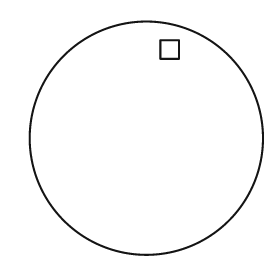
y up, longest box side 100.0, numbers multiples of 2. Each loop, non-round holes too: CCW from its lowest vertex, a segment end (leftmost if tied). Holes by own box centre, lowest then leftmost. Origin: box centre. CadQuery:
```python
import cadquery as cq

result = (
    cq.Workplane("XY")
    .moveTo(0.0, 0.0)
    .circle(50.0)
    .moveTo(6.0, 34.0)
    .lineTo(14.0, 34.0)
    .lineTo(14.0, 42.0)
    .lineTo(6.0, 42.0)
    .close()
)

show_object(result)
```